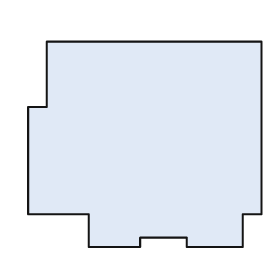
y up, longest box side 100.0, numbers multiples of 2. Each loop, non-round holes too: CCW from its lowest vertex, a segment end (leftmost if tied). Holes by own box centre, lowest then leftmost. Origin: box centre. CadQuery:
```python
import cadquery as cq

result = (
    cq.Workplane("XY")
    .moveTo(-24.0, -44.0)
    .lineTo(-2.0, -44.0)
    .lineTo(-2.0, -40.0)
    .lineTo(18.0, -40.0)
    .lineTo(18.0, -44.0)
    .lineTo(42.0, -44.0)
    .lineTo(42.0, -30.0)
    .lineTo(50.0, -30.0)
    .lineTo(50.0, 44.0)
    .lineTo(-42.0, 44.0)
    .lineTo(-42.0, 16.0)
    .lineTo(-50.0, 16.0)
    .lineTo(-50.0, -30.0)
    .lineTo(-24.0, -30.0)
    .close()
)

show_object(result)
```